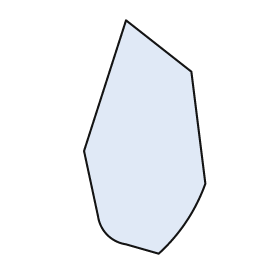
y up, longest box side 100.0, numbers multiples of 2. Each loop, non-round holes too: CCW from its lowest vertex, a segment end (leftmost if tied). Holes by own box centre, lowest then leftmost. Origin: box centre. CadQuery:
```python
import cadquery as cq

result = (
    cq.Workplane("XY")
    .moveTo(6.0, -50.0)
    .threePointArc((18.0, -36.0), (26.0, -20.0))
    .lineTo(20.0, 28.0)
    .lineTo(-8.0, 50.0)
    .lineTo(-26.0, -6.0)
    .lineTo(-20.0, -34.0)
    .threePointArc((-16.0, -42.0), (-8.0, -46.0))
    .close()
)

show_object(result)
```